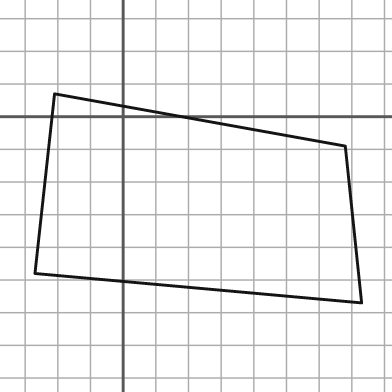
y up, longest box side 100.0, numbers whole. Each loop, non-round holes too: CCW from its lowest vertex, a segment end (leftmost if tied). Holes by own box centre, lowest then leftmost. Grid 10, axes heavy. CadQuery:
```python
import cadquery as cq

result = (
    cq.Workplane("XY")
    .moveTo(73.0, -57.0)
    .lineTo(68.0, -9.0)
    .lineTo(-21.0, 7.0)
    .lineTo(-27.0, -48.0)
    .close()
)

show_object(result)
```